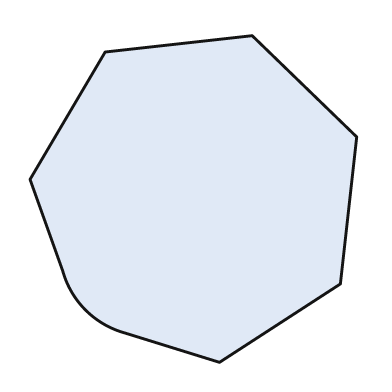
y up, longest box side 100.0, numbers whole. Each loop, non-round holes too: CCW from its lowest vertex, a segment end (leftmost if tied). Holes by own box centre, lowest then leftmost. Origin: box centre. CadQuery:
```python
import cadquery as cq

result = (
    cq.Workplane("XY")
    .moveTo(8.0, -50.0)
    .lineTo(45.0, -26.0)
    .lineTo(50.0, 19.0)
    .lineTo(18.0, 50.0)
    .lineTo(-27.0, 45.0)
    .lineTo(-50.0, 6.0)
    .lineTo(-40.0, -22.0)
    .threePointArc((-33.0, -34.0), (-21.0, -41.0))
    .close()
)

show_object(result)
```